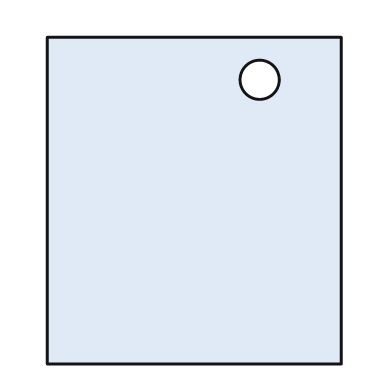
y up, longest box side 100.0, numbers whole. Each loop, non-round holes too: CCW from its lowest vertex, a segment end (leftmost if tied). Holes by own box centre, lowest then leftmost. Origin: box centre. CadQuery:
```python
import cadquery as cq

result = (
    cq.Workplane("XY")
    .moveTo(-45.0, -50.0)
    .lineTo(45.0, -50.0)
    .lineTo(45.0, 50.0)
    .lineTo(-45.0, 50.0)
    .close()
    .moveTo(20.0, 37.0)
    .circle(6.0)
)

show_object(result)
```